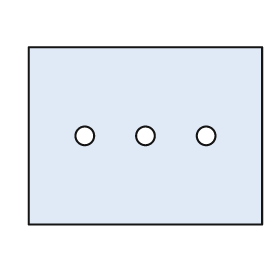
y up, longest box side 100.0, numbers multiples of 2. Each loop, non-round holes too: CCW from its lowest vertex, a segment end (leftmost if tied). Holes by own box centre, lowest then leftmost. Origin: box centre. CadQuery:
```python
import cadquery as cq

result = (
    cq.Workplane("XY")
    .moveTo(-50.0, -38.0)
    .lineTo(50.0, -38.0)
    .lineTo(50.0, 38.0)
    .lineTo(-50.0, 38.0)
    .close()
    .moveTo(-26.0, 0.0)
    .circle(4.0)
    .moveTo(0.0, 0.0)
    .circle(4.0)
    .moveTo(26.0, 0.0)
    .circle(4.0)
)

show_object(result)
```